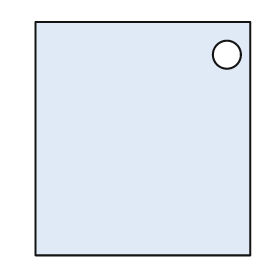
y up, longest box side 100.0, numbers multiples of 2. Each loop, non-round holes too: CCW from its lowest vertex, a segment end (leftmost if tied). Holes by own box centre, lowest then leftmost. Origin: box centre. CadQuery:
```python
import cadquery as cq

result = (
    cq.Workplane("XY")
    .moveTo(-46.0, -50.0)
    .lineTo(46.0, -50.0)
    .lineTo(46.0, 50.0)
    .lineTo(-46.0, 50.0)
    .close()
    .moveTo(36.0, 36.0)
    .circle(6.0)
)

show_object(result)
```